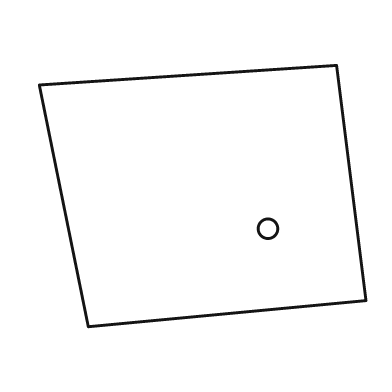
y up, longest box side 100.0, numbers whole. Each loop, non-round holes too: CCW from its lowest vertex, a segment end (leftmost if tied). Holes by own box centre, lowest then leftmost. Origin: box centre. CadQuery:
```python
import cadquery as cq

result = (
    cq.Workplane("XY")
    .moveTo(-35.0, -40.0)
    .lineTo(50.0, -32.0)
    .lineTo(41.0, 40.0)
    .lineTo(-50.0, 34.0)
    .close()
    .moveTo(20.0, -10.0)
    .circle(3.0)
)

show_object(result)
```